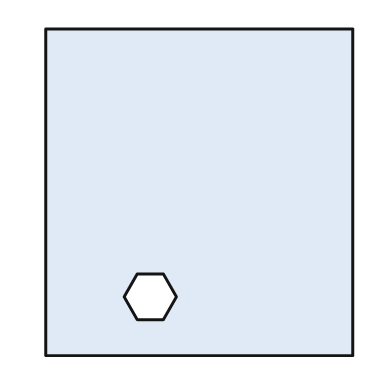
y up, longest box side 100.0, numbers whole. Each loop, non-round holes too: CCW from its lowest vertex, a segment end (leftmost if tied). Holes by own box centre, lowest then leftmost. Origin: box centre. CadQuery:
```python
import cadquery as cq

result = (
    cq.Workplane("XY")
    .moveTo(-47.0, -50.0)
    .lineTo(47.0, -50.0)
    .lineTo(47.0, 50.0)
    .lineTo(-47.0, 50.0)
    .close()
    .moveTo(-19.0, -39.0)
    .lineTo(-11.0, -39.0)
    .lineTo(-7.0, -32.0)
    .lineTo(-11.0, -25.0)
    .lineTo(-19.0, -25.0)
    .lineTo(-23.0, -32.0)
    .close()
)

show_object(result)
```